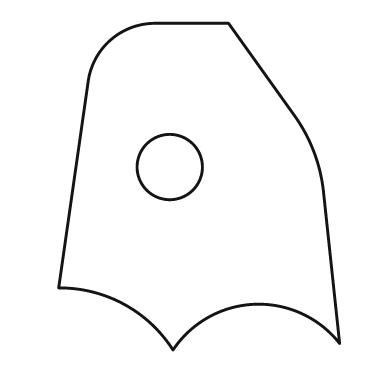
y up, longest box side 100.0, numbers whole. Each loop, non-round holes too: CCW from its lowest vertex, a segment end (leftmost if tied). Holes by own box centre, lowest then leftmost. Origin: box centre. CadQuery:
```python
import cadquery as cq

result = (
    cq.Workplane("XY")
    .moveTo(-8.0, -50.0)
    .threePointArc((17.0, -36.0), (43.0, -48.0))
    .lineTo(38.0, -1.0)
    .threePointArc((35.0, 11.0), (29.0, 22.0))
    .lineTo(9.0, 50.0)
    .lineTo(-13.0, 50.0)
    .threePointArc((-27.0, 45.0), (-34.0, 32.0))
    .lineTo(-43.0, -31.0)
    .threePointArc((-23.0, -36.0), (-8.0, -50.0))
    .close()
    .moveTo(-9.0, 6.0)
    .circle(10.0)
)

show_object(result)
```